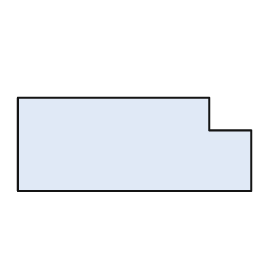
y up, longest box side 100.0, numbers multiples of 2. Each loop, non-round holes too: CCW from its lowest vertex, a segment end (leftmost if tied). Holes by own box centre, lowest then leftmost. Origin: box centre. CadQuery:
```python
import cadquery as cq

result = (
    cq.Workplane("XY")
    .moveTo(-50.0, -20.0)
    .lineTo(50.0, -20.0)
    .lineTo(50.0, 6.0)
    .lineTo(32.0, 6.0)
    .lineTo(32.0, 20.0)
    .lineTo(-50.0, 20.0)
    .close()
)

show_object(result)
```